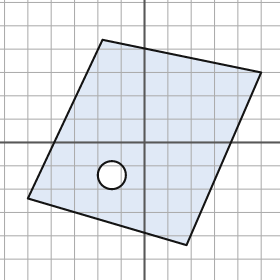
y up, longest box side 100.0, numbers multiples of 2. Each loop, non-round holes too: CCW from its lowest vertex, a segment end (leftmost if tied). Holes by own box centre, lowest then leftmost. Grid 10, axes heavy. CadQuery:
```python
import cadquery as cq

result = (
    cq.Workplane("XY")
    .moveTo(18.0, -44.0)
    .lineTo(50.0, 30.0)
    .lineTo(-18.0, 44.0)
    .lineTo(-50.0, -24.0)
    .close()
    .moveTo(-14.0, -14.0)
    .circle(6.0)
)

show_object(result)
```